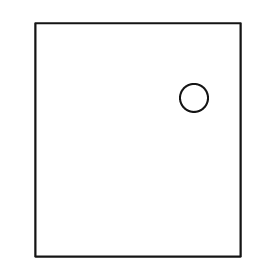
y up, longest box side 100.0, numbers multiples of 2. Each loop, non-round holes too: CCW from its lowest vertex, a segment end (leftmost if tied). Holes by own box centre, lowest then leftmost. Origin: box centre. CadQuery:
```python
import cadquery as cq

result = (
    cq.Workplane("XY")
    .moveTo(-44.0, -50.0)
    .lineTo(44.0, -50.0)
    .lineTo(44.0, 50.0)
    .lineTo(-44.0, 50.0)
    .close()
    .moveTo(24.0, 18.0)
    .circle(6.0)
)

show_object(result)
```